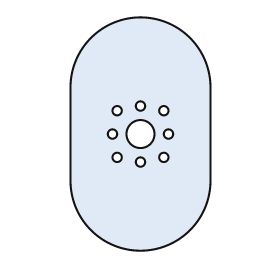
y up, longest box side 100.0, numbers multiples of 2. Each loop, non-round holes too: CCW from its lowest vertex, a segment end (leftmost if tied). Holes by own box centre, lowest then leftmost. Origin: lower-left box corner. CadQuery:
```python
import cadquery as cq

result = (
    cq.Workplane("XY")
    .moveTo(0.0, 30.0)
    .threePointArc((30.0, 0.0), (60.0, 30.0))
    .lineTo(60.0, 70.0)
    .threePointArc((30.0, 100.0), (0.0, 70.0))
    .close()
    .moveTo(30.0, 38.0)
    .circle(2.0)
    .moveTo(20.0, 40.0)
    .circle(2.0)
    .moveTo(40.0, 40.0)
    .circle(2.0)
    .moveTo(18.0, 50.0)
    .circle(2.0)
    .moveTo(30.0, 50.0)
    .circle(6.0)
    .moveTo(42.0, 50.0)
    .circle(2.0)
    .moveTo(20.0, 60.0)
    .circle(2.0)
    .moveTo(40.0, 60.0)
    .circle(2.0)
    .moveTo(30.0, 62.0)
    .circle(2.0)
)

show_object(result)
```